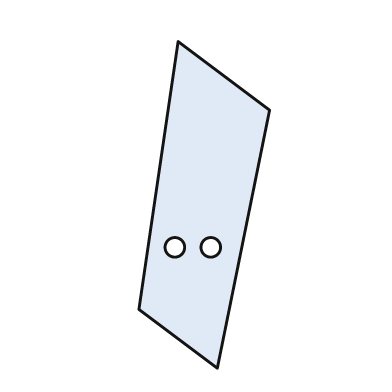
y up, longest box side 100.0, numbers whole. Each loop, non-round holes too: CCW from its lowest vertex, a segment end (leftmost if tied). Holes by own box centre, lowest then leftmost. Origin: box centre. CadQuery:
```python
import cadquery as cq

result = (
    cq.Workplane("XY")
    .moveTo(4.0, -50.0)
    .lineTo(20.0, 29.0)
    .lineTo(-8.0, 50.0)
    .lineTo(-20.0, -32.0)
    .close()
    .moveTo(-9.0, -13.0)
    .circle(3.0)
    .moveTo(2.0, -13.0)
    .circle(3.0)
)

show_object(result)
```